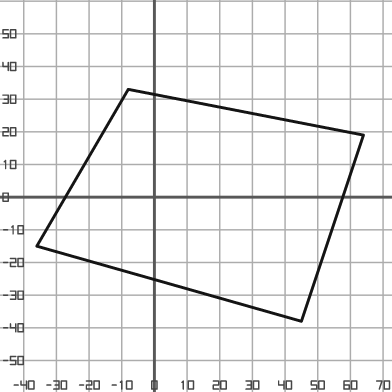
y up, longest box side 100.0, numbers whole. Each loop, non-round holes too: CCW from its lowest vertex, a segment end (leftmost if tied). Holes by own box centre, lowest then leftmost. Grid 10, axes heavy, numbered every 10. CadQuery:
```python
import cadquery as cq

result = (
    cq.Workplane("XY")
    .moveTo(45.0, -38.0)
    .lineTo(64.0, 19.0)
    .lineTo(-8.0, 33.0)
    .lineTo(-36.0, -15.0)
    .close()
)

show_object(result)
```